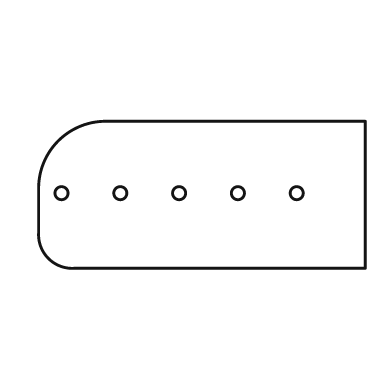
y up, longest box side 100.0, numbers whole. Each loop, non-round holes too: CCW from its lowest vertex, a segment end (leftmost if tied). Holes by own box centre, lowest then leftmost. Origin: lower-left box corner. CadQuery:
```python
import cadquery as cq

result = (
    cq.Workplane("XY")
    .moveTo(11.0, 0.0)
    .lineTo(100.0, 0.0)
    .lineTo(100.0, 45.0)
    .lineTo(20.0, 45.0)
    .threePointArc((6.0, 39.0), (0.0, 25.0))
    .lineTo(0.0, 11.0)
    .threePointArc((3.0, 3.0), (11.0, 0.0))
    .close()
    .moveTo(7.0, 23.0)
    .circle(2.0)
    .moveTo(25.0, 23.0)
    .circle(2.0)
    .moveTo(43.0, 23.0)
    .circle(2.0)
    .moveTo(61.0, 23.0)
    .circle(2.0)
    .moveTo(79.0, 23.0)
    .circle(2.0)
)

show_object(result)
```